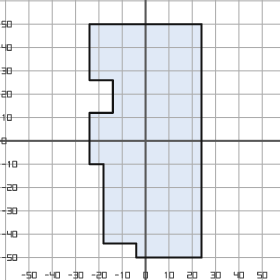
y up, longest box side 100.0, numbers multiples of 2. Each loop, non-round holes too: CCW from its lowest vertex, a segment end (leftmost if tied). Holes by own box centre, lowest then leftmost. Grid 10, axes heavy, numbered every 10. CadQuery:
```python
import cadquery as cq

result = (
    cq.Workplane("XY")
    .moveTo(-4.0, -50.0)
    .lineTo(24.0, -50.0)
    .lineTo(24.0, 50.0)
    .lineTo(-24.0, 50.0)
    .lineTo(-24.0, 26.0)
    .lineTo(-14.0, 26.0)
    .lineTo(-14.0, 12.0)
    .lineTo(-24.0, 12.0)
    .lineTo(-24.0, -10.0)
    .lineTo(-18.0, -10.0)
    .lineTo(-18.0, -44.0)
    .lineTo(-4.0, -44.0)
    .close()
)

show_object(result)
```